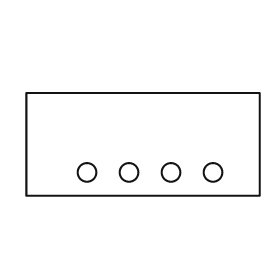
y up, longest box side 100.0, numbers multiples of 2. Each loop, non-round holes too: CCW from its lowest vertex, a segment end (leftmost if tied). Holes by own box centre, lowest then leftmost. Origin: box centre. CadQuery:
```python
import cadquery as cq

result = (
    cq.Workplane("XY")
    .moveTo(-50.0, -22.0)
    .lineTo(50.0, -22.0)
    .lineTo(50.0, 22.0)
    .lineTo(-50.0, 22.0)
    .close()
    .moveTo(-24.0, -12.0)
    .circle(4.0)
    .moveTo(-6.0, -12.0)
    .circle(4.0)
    .moveTo(12.0, -12.0)
    .circle(4.0)
    .moveTo(30.0, -12.0)
    .circle(4.0)
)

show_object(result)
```